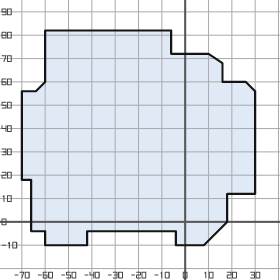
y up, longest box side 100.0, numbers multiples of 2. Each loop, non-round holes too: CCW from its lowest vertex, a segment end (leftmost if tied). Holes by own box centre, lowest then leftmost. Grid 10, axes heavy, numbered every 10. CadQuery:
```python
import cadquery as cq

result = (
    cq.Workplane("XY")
    .moveTo(-60.0, -10.0)
    .lineTo(-42.0, -10.0)
    .lineTo(-42.0, -4.0)
    .lineTo(-4.0, -4.0)
    .lineTo(-4.0, -10.0)
    .lineTo(8.0, -10.0)
    .lineTo(18.0, 0.0)
    .lineTo(18.0, 12.0)
    .lineTo(30.0, 12.0)
    .lineTo(30.0, 56.0)
    .lineTo(26.0, 60.0)
    .lineTo(16.0, 60.0)
    .lineTo(16.0, 68.0)
    .lineTo(10.0, 72.0)
    .lineTo(-6.0, 72.0)
    .lineTo(-6.0, 82.0)
    .lineTo(-60.0, 82.0)
    .lineTo(-60.0, 60.0)
    .lineTo(-64.0, 56.0)
    .lineTo(-70.0, 56.0)
    .lineTo(-70.0, 18.0)
    .lineTo(-66.0, 18.0)
    .lineTo(-66.0, -4.0)
    .lineTo(-60.0, -4.0)
    .close()
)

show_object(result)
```